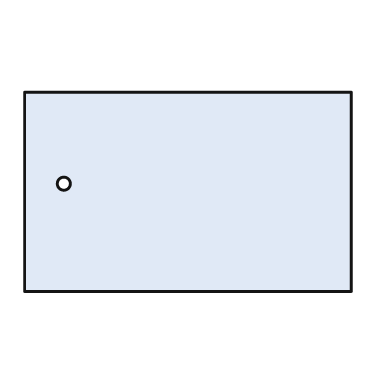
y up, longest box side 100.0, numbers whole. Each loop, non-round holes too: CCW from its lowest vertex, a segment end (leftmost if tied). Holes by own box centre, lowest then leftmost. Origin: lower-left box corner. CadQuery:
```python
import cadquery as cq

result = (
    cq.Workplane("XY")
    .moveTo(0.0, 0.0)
    .lineTo(100.0, 0.0)
    .lineTo(100.0, 61.0)
    .lineTo(0.0, 61.0)
    .close()
    .moveTo(12.0, 33.0)
    .circle(2.0)
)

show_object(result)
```